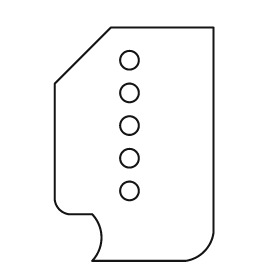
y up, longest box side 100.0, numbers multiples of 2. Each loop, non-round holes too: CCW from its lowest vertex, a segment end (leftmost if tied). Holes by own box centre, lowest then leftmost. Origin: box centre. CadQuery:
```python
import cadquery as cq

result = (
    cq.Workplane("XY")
    .moveTo(-18.0, -50.0)
    .lineTo(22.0, -50.0)
    .threePointArc((30.0, -46.0), (34.0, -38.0))
    .lineTo(34.0, 50.0)
    .lineTo(-10.0, 50.0)
    .lineTo(-34.0, 26.0)
    .lineTo(-34.0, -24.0)
    .threePointArc((-32.0, -28.0), (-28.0, -30.0))
    .lineTo(-18.0, -30.0)
    .threePointArc((-14.0, -40.0), (-18.0, -50.0))
    .close()
    .moveTo(-2.0, -20.0)
    .circle(4.0)
    .moveTo(-2.0, -6.0)
    .circle(4.0)
    .moveTo(-2.0, 8.0)
    .circle(4.0)
    .moveTo(-2.0, 22.0)
    .circle(4.0)
    .moveTo(-2.0, 36.0)
    .circle(4.0)
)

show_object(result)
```